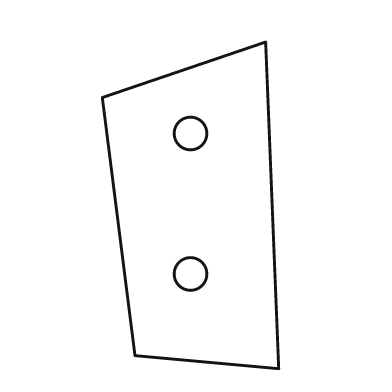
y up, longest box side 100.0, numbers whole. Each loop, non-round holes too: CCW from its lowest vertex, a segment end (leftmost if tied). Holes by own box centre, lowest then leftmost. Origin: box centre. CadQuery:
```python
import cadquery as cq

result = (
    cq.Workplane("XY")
    .moveTo(27.0, -50.0)
    .lineTo(23.0, 50.0)
    .lineTo(-27.0, 33.0)
    .lineTo(-17.0, -46.0)
    .close()
    .moveTo(0.0, -21.0)
    .circle(5.0)
    .moveTo(0.0, 22.0)
    .circle(5.0)
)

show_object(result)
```